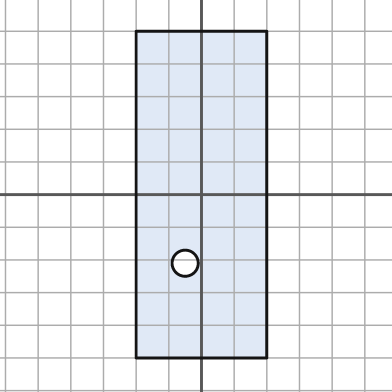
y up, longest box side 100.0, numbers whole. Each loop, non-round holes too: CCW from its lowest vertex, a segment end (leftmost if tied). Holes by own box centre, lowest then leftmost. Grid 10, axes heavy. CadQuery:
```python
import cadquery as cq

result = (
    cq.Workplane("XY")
    .moveTo(-20.0, -50.0)
    .lineTo(20.0, -50.0)
    .lineTo(20.0, 50.0)
    .lineTo(-20.0, 50.0)
    .close()
    .moveTo(-5.0, -21.0)
    .circle(4.0)
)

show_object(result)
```